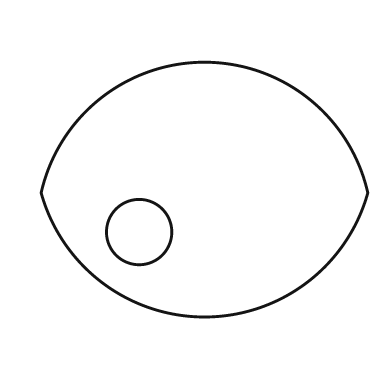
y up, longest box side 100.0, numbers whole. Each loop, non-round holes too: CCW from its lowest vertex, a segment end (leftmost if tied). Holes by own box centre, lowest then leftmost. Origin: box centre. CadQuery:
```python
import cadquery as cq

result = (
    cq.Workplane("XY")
    .moveTo(-50.0, -1.0)
    .threePointArc((0.0, -39.0), (50.0, -1.0))
    .threePointArc((0.0, 39.0), (-50.0, -1.0))
    .close()
    .moveTo(-20.0, -13.0)
    .circle(10.0)
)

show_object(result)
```